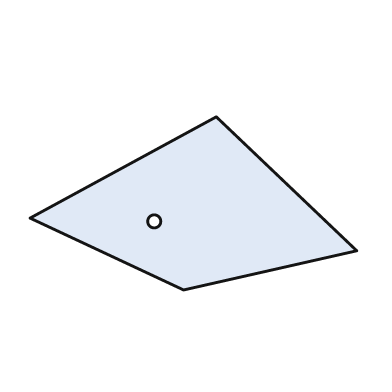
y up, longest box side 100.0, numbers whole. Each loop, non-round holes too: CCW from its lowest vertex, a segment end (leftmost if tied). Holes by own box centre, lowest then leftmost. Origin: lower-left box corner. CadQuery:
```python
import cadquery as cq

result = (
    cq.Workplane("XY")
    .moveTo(47.0, 0.0)
    .lineTo(100.0, 12.0)
    .lineTo(57.0, 53.0)
    .lineTo(0.0, 22.0)
    .close()
    .moveTo(38.0, 21.0)
    .circle(2.0)
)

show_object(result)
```